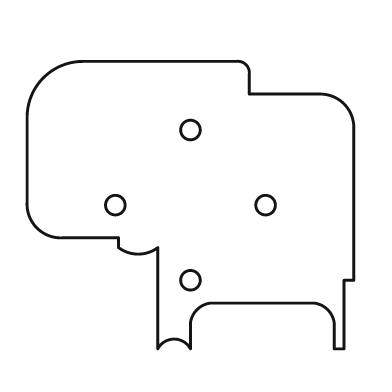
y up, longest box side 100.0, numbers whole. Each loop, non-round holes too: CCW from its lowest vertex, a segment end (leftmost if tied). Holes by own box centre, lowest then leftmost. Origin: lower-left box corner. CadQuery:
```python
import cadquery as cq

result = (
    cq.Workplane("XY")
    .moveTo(40.0, 0.0)
    .threePointArc((45.0, 3.0), (50.0, 0.0))
    .lineTo(50.0, 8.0)
    .threePointArc((52.0, 12.0), (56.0, 14.0))
    .lineTo(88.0, 14.0)
    .threePointArc((92.0, 12.0), (94.0, 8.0))
    .lineTo(94.0, 0.0)
    .lineTo(97.0, 0.0)
    .lineTo(97.0, 21.0)
    .lineTo(100.0, 21.0)
    .lineTo(100.0, 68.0)
    .threePointArc((97.0, 75.0), (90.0, 78.0))
    .lineTo(68.0, 78.0)
    .lineTo(68.0, 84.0)
    .threePointArc((67.0, 87.0), (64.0, 88.0))
    .lineTo(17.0, 88.0)
    .threePointArc((5.0, 83.0), (0.0, 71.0))
    .lineTo(0.0, 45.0)
    .threePointArc((3.0, 37.0), (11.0, 34.0))
    .lineTo(28.0, 34.0)
    .lineTo(28.0, 31.0)
    .threePointArc((34.0, 29.0), (40.0, 31.0))
    .close()
    .moveTo(50.0, 21.0)
    .circle(3.0)
    .moveTo(27.0, 44.0)
    .circle(3.0)
    .moveTo(73.0, 44.0)
    .circle(3.0)
    .moveTo(50.0, 67.0)
    .circle(3.0)
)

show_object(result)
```